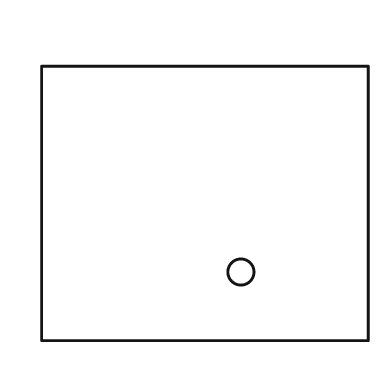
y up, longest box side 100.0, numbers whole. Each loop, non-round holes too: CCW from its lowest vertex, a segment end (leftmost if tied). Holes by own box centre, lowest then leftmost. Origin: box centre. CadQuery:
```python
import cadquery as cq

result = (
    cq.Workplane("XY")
    .moveTo(-50.0, -42.0)
    .lineTo(50.0, -42.0)
    .lineTo(50.0, 42.0)
    .lineTo(-50.0, 42.0)
    .close()
    .moveTo(11.0, -21.0)
    .circle(4.0)
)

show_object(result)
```